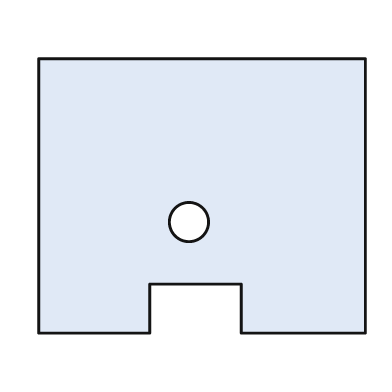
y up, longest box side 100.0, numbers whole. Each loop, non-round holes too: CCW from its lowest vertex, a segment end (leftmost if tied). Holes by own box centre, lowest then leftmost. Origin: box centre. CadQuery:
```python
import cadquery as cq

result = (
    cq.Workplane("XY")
    .moveTo(-50.0, -42.0)
    .lineTo(-16.0, -42.0)
    .lineTo(-16.0, -27.0)
    .lineTo(12.0, -27.0)
    .lineTo(12.0, -42.0)
    .lineTo(50.0, -42.0)
    .lineTo(50.0, 42.0)
    .lineTo(-50.0, 42.0)
    .close()
    .moveTo(-4.0, -8.0)
    .circle(6.0)
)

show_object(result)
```